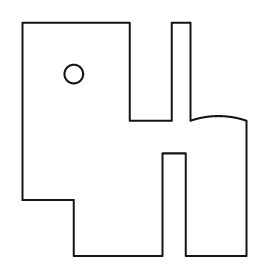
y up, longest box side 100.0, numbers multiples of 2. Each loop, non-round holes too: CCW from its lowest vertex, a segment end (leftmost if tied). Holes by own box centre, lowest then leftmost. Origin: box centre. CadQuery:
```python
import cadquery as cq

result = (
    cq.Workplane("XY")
    .moveTo(-26.0, -50.0)
    .lineTo(12.0, -50.0)
    .lineTo(12.0, -6.0)
    .lineTo(22.0, -6.0)
    .lineTo(22.0, -50.0)
    .lineTo(48.0, -50.0)
    .lineTo(48.0, 8.0)
    .threePointArc((36.0, 10.0), (24.0, 8.0))
    .lineTo(24.0, 50.0)
    .lineTo(16.0, 50.0)
    .lineTo(16.0, 8.0)
    .lineTo(-2.0, 8.0)
    .lineTo(-2.0, 50.0)
    .lineTo(-48.0, 50.0)
    .lineTo(-48.0, -26.0)
    .lineTo(-26.0, -26.0)
    .close()
    .moveTo(-26.0, 28.0)
    .circle(4.0)
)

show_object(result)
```